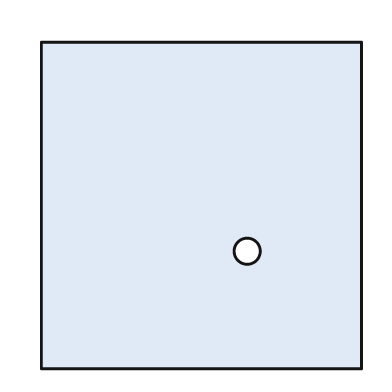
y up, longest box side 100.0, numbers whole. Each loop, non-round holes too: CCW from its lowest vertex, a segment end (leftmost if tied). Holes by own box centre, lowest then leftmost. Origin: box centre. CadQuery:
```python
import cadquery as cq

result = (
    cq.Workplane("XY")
    .moveTo(-49.0, -50.0)
    .lineTo(49.0, -50.0)
    .lineTo(49.0, 50.0)
    .lineTo(-49.0, 50.0)
    .close()
    .moveTo(14.0, -14.0)
    .circle(4.0)
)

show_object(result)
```